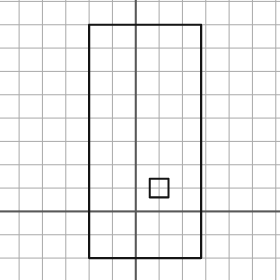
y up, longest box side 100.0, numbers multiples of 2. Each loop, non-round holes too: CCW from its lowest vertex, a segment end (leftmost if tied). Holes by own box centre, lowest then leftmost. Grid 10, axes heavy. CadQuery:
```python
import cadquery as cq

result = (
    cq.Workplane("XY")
    .moveTo(-20.0, -20.0)
    .lineTo(28.0, -20.0)
    .lineTo(28.0, 80.0)
    .lineTo(-20.0, 80.0)
    .close()
    .moveTo(6.0, 6.0)
    .lineTo(14.0, 6.0)
    .lineTo(14.0, 14.0)
    .lineTo(6.0, 14.0)
    .close()
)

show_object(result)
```